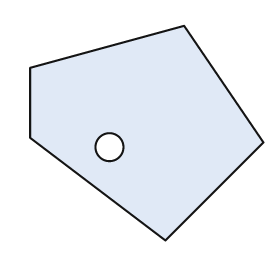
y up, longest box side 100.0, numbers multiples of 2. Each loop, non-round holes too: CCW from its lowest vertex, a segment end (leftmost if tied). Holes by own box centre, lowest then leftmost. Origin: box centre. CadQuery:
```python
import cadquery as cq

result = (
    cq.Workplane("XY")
    .moveTo(8.0, -46.0)
    .lineTo(50.0, -4.0)
    .lineTo(16.0, 46.0)
    .lineTo(-50.0, 28.0)
    .lineTo(-50.0, -2.0)
    .close()
    .moveTo(-16.0, -6.0)
    .circle(6.0)
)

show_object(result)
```